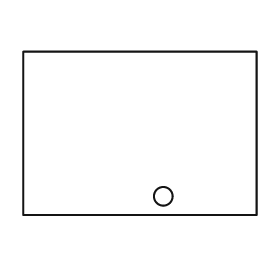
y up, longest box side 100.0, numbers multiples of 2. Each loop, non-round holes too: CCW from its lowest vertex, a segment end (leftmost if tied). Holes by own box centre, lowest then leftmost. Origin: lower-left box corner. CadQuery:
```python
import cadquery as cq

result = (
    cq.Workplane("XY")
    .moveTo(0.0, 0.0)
    .lineTo(100.0, 0.0)
    .lineTo(100.0, 70.0)
    .lineTo(0.0, 70.0)
    .close()
    .moveTo(60.0, 8.0)
    .circle(4.0)
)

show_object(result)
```